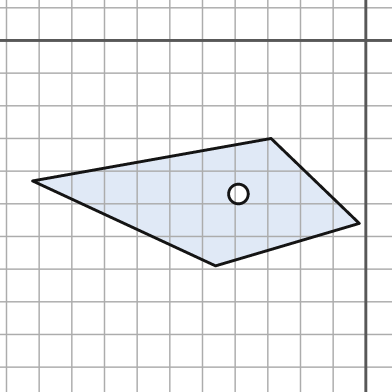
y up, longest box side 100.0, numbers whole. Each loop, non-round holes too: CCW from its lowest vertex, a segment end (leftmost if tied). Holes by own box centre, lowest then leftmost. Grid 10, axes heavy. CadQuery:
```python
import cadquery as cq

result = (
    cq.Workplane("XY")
    .moveTo(-46.0, -69.0)
    .lineTo(-2.0, -56.0)
    .lineTo(-29.0, -30.0)
    .lineTo(-102.0, -43.0)
    .close()
    .moveTo(-39.0, -47.0)
    .circle(3.0)
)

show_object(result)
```